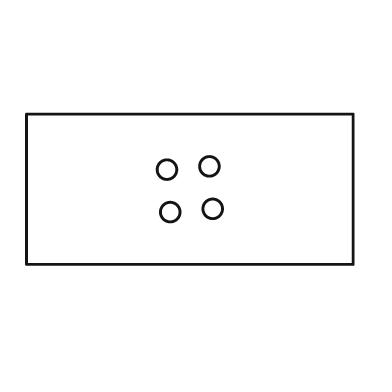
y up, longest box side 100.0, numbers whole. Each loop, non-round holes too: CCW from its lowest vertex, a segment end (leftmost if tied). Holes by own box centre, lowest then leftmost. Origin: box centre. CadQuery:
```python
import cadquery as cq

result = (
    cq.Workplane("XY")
    .moveTo(-50.0, -23.0)
    .lineTo(50.0, -23.0)
    .lineTo(50.0, 23.0)
    .lineTo(-50.0, 23.0)
    .close()
    .moveTo(-6.0, -7.0)
    .circle(3.0)
    .moveTo(7.0, -6.0)
    .circle(3.0)
    .moveTo(-7.0, 6.0)
    .circle(3.0)
    .moveTo(6.0, 7.0)
    .circle(3.0)
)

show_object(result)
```